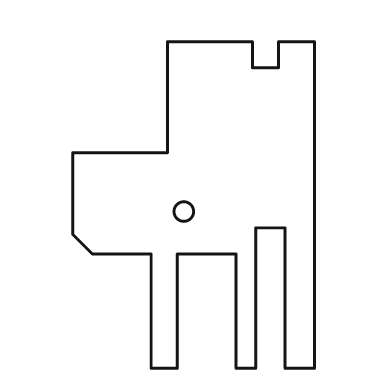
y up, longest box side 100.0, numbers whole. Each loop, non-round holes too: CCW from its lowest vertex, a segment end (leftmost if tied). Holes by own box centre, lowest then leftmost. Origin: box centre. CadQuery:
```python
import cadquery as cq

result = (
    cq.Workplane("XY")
    .moveTo(-13.0, -50.0)
    .lineTo(-5.0, -50.0)
    .lineTo(-5.0, -15.0)
    .lineTo(13.0, -15.0)
    .lineTo(13.0, -50.0)
    .lineTo(19.0, -50.0)
    .lineTo(19.0, -7.0)
    .lineTo(28.0, -7.0)
    .lineTo(28.0, -50.0)
    .lineTo(37.0, -50.0)
    .lineTo(37.0, 50.0)
    .lineTo(26.0, 50.0)
    .lineTo(26.0, 42.0)
    .lineTo(18.0, 42.0)
    .lineTo(18.0, 50.0)
    .lineTo(-8.0, 50.0)
    .lineTo(-8.0, 16.0)
    .lineTo(-37.0, 16.0)
    .lineTo(-37.0, -9.0)
    .lineTo(-31.0, -15.0)
    .lineTo(-13.0, -15.0)
    .close()
    .moveTo(-3.0, -2.0)
    .circle(3.0)
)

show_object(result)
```